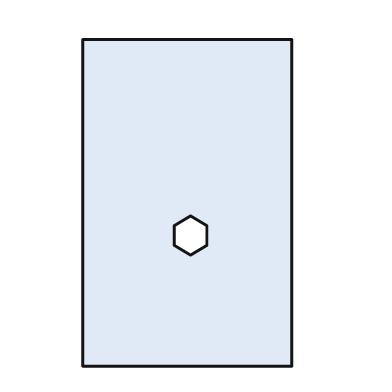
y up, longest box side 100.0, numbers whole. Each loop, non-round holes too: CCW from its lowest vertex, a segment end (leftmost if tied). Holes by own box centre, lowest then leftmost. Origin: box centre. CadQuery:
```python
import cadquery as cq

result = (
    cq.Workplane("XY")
    .moveTo(-32.0, -50.0)
    .lineTo(32.0, -50.0)
    .lineTo(32.0, 50.0)
    .lineTo(-32.0, 50.0)
    .close()
    .moveTo(1.0, -16.0)
    .lineTo(6.0, -13.0)
    .lineTo(6.0, -7.0)
    .lineTo(1.0, -4.0)
    .lineTo(-4.0, -7.0)
    .lineTo(-4.0, -13.0)
    .close()
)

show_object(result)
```